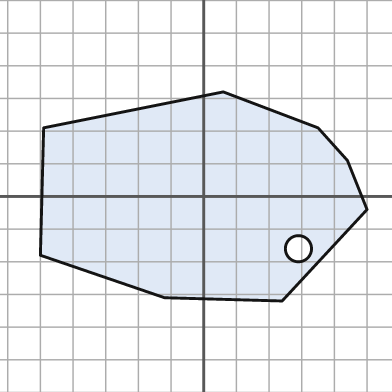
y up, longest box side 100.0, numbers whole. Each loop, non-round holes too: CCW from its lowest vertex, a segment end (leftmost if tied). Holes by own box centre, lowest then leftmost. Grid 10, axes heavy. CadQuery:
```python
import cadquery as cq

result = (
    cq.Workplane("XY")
    .moveTo(24.0, -32.0)
    .lineTo(50.0, -4.0)
    .lineTo(44.0, 11.0)
    .lineTo(35.0, 21.0)
    .lineTo(6.0, 32.0)
    .lineTo(-49.0, 21.0)
    .lineTo(-50.0, -18.0)
    .lineTo(-12.0, -31.0)
    .close()
    .moveTo(29.0, -16.0)
    .circle(4.0)
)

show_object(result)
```